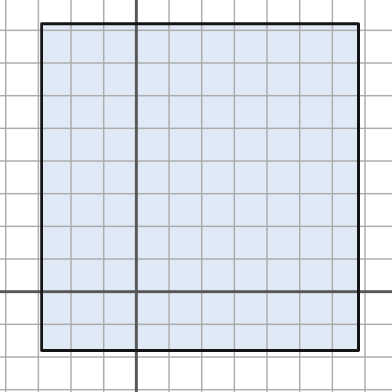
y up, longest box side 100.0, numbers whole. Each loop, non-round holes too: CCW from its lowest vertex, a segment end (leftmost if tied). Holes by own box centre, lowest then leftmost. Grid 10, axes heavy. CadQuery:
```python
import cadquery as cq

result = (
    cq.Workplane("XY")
    .moveTo(-29.0, -18.0)
    .lineTo(68.0, -18.0)
    .lineTo(68.0, 82.0)
    .lineTo(-29.0, 82.0)
    .close()
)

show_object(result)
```